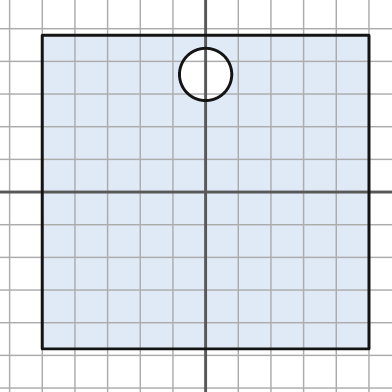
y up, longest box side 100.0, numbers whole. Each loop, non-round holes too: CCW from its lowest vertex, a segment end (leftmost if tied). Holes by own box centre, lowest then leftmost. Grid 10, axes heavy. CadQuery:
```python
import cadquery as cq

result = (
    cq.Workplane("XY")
    .moveTo(-50.0, -48.0)
    .lineTo(50.0, -48.0)
    .lineTo(50.0, 48.0)
    .lineTo(-50.0, 48.0)
    .close()
    .moveTo(0.0, 36.0)
    .circle(8.0)
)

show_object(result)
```